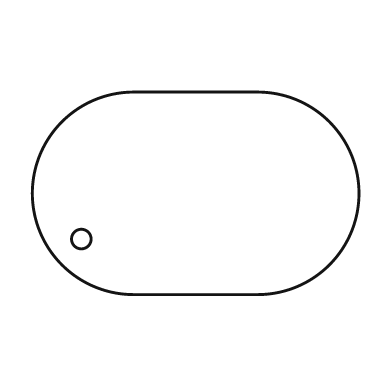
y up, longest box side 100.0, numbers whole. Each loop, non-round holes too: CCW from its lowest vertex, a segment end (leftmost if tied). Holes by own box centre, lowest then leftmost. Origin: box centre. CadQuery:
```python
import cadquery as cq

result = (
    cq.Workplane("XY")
    .moveTo(-19.0, -31.0)
    .lineTo(19.0, -31.0)
    .threePointArc((50.0, 0.0), (19.0, 31.0))
    .lineTo(-19.0, 31.0)
    .threePointArc((-50.0, 0.0), (-19.0, -31.0))
    .close()
    .moveTo(-35.0, -14.0)
    .circle(3.0)
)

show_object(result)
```